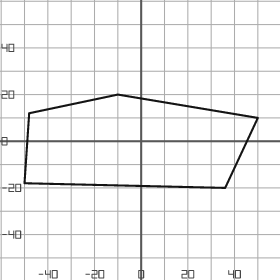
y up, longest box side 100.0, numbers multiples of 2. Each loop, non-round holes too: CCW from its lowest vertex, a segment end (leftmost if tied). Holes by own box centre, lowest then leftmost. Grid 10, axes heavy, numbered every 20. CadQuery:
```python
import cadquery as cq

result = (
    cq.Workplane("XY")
    .moveTo(36.0, -20.0)
    .lineTo(50.0, 10.0)
    .lineTo(-10.0, 20.0)
    .lineTo(-48.0, 12.0)
    .lineTo(-50.0, -18.0)
    .close()
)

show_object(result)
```